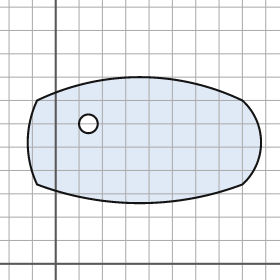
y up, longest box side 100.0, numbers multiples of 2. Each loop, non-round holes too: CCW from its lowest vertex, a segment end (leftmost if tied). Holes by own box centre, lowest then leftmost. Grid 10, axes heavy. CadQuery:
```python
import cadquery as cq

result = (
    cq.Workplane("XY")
    .moveTo(-8.0, 34.0)
    .threePointArc((36.0, 26.0), (80.0, 34.0))
    .threePointArc((88.0, 52.0), (80.0, 70.0))
    .threePointArc((36.0, 80.0), (-8.0, 70.0))
    .threePointArc((-12.0, 52.0), (-8.0, 34.0))
    .close()
    .moveTo(14.0, 60.0)
    .circle(4.0)
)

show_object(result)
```